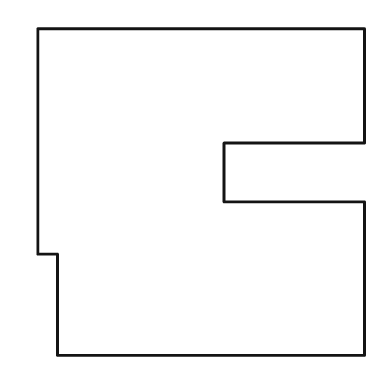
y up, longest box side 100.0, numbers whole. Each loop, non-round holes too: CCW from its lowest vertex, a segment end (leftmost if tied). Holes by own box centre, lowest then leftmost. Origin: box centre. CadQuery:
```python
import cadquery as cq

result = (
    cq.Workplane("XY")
    .moveTo(-44.0, -50.0)
    .lineTo(50.0, -50.0)
    .lineTo(50.0, -3.0)
    .lineTo(7.0, -3.0)
    .lineTo(7.0, 15.0)
    .lineTo(50.0, 15.0)
    .lineTo(50.0, 50.0)
    .lineTo(-50.0, 50.0)
    .lineTo(-50.0, -19.0)
    .lineTo(-44.0, -19.0)
    .close()
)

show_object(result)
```